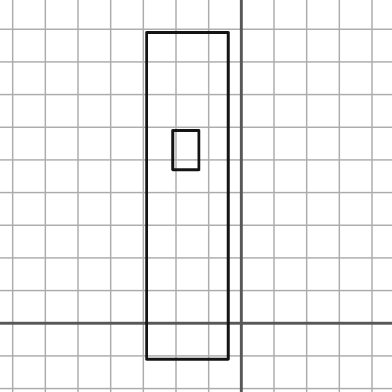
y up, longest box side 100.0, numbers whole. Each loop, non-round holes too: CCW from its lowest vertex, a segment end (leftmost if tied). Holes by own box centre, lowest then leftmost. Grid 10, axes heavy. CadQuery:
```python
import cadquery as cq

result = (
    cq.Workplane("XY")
    .moveTo(-29.0, -11.0)
    .lineTo(-4.0, -11.0)
    .lineTo(-4.0, 89.0)
    .lineTo(-29.0, 89.0)
    .close()
    .moveTo(-21.0, 47.0)
    .lineTo(-13.0, 47.0)
    .lineTo(-13.0, 59.0)
    .lineTo(-21.0, 59.0)
    .close()
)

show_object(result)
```